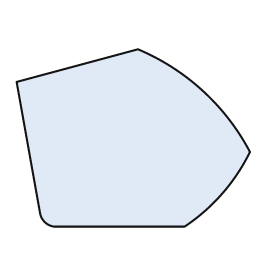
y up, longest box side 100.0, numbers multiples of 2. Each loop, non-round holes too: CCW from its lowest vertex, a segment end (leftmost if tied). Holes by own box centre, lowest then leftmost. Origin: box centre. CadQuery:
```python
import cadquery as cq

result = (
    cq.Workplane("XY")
    .moveTo(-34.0, -38.0)
    .lineTo(22.0, -38.0)
    .threePointArc((38.0, -24.0), (50.0, -6.0))
    .threePointArc((30.0, 20.0), (2.0, 38.0))
    .lineTo(-50.0, 24.0)
    .lineTo(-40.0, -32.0)
    .threePointArc((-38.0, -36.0), (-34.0, -38.0))
    .close()
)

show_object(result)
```